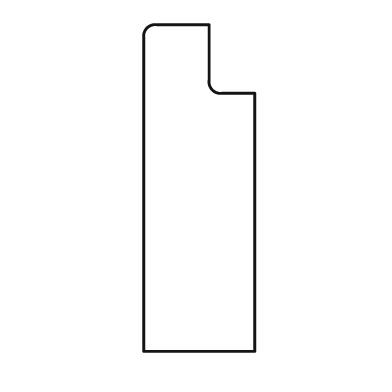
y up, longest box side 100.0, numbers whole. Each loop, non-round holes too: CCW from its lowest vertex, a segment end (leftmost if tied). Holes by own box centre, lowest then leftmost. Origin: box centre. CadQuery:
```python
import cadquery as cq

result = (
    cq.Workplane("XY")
    .moveTo(-17.0, -50.0)
    .lineTo(17.0, -50.0)
    .lineTo(17.0, 29.0)
    .lineTo(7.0, 29.0)
    .threePointArc((4.0, 30.0), (3.0, 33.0))
    .lineTo(3.0, 50.0)
    .lineTo(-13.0, 50.0)
    .threePointArc((-16.0, 49.0), (-17.0, 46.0))
    .close()
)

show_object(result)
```